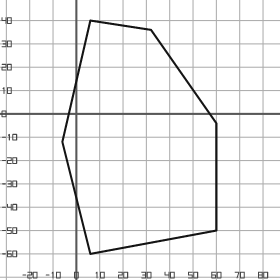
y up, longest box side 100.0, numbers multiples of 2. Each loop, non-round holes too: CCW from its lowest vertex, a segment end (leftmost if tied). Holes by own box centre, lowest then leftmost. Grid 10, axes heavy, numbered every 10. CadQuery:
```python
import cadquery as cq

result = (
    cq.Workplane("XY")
    .moveTo(6.0, -60.0)
    .lineTo(60.0, -50.0)
    .lineTo(60.0, -4.0)
    .lineTo(32.0, 36.0)
    .lineTo(6.0, 40.0)
    .lineTo(-6.0, -12.0)
    .close()
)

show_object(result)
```